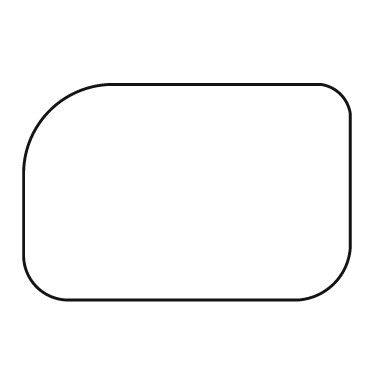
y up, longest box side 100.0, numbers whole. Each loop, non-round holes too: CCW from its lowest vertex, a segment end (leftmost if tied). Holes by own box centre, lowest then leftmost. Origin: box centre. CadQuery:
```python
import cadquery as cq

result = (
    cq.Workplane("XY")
    .moveTo(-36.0, -33.0)
    .lineTo(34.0, -33.0)
    .threePointArc((45.0, -28.0), (50.0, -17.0))
    .lineTo(50.0, 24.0)
    .threePointArc((47.0, 30.0), (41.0, 33.0))
    .lineTo(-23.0, 33.0)
    .threePointArc((-42.0, 25.0), (-50.0, 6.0))
    .lineTo(-50.0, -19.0)
    .threePointArc((-46.0, -29.0), (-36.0, -33.0))
    .close()
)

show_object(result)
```